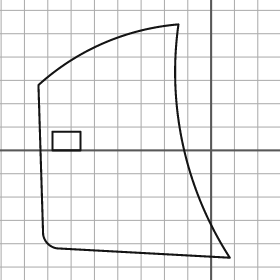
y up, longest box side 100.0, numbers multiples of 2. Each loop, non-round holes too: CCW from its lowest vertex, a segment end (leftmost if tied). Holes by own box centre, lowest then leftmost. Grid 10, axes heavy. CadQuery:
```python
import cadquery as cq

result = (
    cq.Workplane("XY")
    .moveTo(8.0, -46.0)
    .threePointArc((-12.0, 2.0), (-14.0, 54.0))
    .threePointArc((-46.0, 46.0), (-74.0, 28.0))
    .lineTo(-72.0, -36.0)
    .threePointArc((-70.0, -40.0), (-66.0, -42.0))
    .close()
    .moveTo(-68.0, 0.0)
    .lineTo(-56.0, 0.0)
    .lineTo(-56.0, 8.0)
    .lineTo(-68.0, 8.0)
    .close()
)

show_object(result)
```